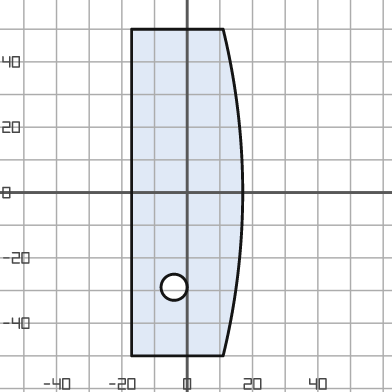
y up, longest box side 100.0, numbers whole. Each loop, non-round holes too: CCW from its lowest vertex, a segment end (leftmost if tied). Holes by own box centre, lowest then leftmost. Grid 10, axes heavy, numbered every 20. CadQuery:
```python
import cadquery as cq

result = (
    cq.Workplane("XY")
    .moveTo(-17.0, -50.0)
    .lineTo(11.0, -50.0)
    .threePointArc((17.0, 0.0), (11.0, 50.0))
    .lineTo(-17.0, 50.0)
    .close()
    .moveTo(-4.0, -29.0)
    .circle(4.0)
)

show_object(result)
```